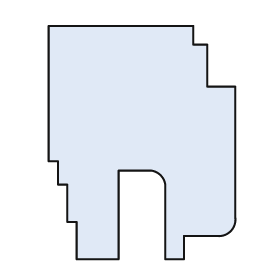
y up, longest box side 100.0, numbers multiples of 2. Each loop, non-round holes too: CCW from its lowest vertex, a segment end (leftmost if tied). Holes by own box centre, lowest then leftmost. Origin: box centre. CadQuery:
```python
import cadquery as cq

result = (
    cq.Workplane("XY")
    .moveTo(-28.0, -50.0)
    .lineTo(-10.0, -50.0)
    .lineTo(-10.0, -12.0)
    .lineTo(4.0, -12.0)
    .threePointArc((8.0, -14.0), (10.0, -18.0))
    .lineTo(10.0, -50.0)
    .lineTo(18.0, -50.0)
    .lineTo(18.0, -40.0)
    .lineTo(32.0, -40.0)
    .threePointArc((38.0, -38.0), (40.0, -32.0))
    .lineTo(40.0, 24.0)
    .lineTo(28.0, 24.0)
    .lineTo(28.0, 42.0)
    .lineTo(22.0, 42.0)
    .lineTo(22.0, 50.0)
    .lineTo(-40.0, 50.0)
    .lineTo(-40.0, -8.0)
    .lineTo(-36.0, -8.0)
    .lineTo(-36.0, -18.0)
    .lineTo(-32.0, -18.0)
    .lineTo(-32.0, -34.0)
    .lineTo(-28.0, -34.0)
    .close()
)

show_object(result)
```